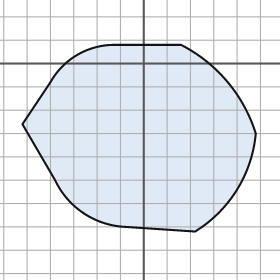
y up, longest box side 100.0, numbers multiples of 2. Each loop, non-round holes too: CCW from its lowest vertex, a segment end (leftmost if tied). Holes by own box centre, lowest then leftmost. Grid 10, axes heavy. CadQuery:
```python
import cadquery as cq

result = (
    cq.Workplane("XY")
    .moveTo(22.0, -72.0)
    .threePointArc((40.0, -54.0), (48.0, -30.0))
    .threePointArc((36.0, -8.0), (16.0, 8.0))
    .lineTo(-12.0, 8.0)
    .threePointArc((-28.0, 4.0), (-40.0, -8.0))
    .lineTo(-52.0, -26.0)
    .lineTo(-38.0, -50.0)
    .threePointArc((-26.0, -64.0), (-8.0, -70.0))
    .close()
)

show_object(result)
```